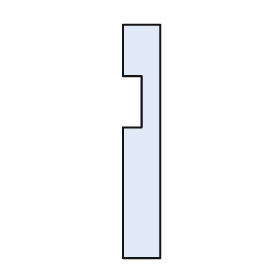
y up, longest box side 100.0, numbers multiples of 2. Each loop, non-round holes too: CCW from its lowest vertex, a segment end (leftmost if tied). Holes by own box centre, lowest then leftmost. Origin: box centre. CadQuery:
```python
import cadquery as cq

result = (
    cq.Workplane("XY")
    .moveTo(-8.0, -50.0)
    .lineTo(8.0, -50.0)
    .lineTo(8.0, 50.0)
    .lineTo(-8.0, 50.0)
    .lineTo(-8.0, 28.0)
    .lineTo(0.0, 28.0)
    .lineTo(0.0, 6.0)
    .lineTo(-8.0, 6.0)
    .close()
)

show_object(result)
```